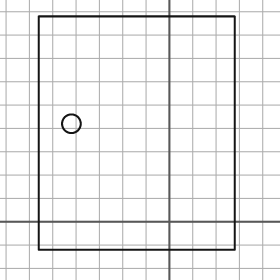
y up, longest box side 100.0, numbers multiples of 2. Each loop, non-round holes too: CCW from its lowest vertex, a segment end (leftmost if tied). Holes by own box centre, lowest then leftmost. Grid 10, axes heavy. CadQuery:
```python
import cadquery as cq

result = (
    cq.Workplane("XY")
    .moveTo(-56.0, -12.0)
    .lineTo(28.0, -12.0)
    .lineTo(28.0, 88.0)
    .lineTo(-56.0, 88.0)
    .close()
    .moveTo(-42.0, 42.0)
    .circle(4.0)
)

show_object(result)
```